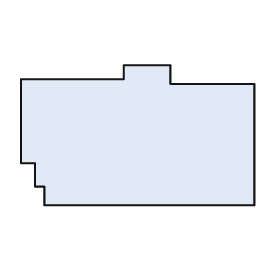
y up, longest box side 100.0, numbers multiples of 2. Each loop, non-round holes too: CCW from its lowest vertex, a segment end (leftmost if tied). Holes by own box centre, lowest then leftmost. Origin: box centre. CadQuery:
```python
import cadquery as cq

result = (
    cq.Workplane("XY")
    .moveTo(-40.0, -30.0)
    .lineTo(50.0, -30.0)
    .lineTo(50.0, 22.0)
    .lineTo(14.0, 22.0)
    .lineTo(14.0, 30.0)
    .lineTo(-6.0, 30.0)
    .lineTo(-6.0, 24.0)
    .lineTo(-50.0, 24.0)
    .lineTo(-50.0, -12.0)
    .lineTo(-44.0, -12.0)
    .lineTo(-44.0, -22.0)
    .lineTo(-40.0, -22.0)
    .close()
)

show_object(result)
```